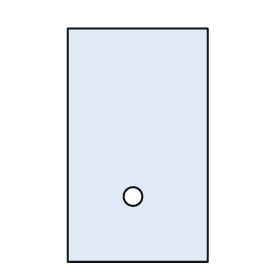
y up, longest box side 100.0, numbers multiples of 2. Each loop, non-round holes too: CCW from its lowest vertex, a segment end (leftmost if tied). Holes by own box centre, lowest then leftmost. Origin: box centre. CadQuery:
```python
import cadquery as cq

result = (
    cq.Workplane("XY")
    .moveTo(-30.0, -50.0)
    .lineTo(30.0, -50.0)
    .lineTo(30.0, 50.0)
    .lineTo(-30.0, 50.0)
    .close()
    .moveTo(-2.0, -22.0)
    .circle(4.0)
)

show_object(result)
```